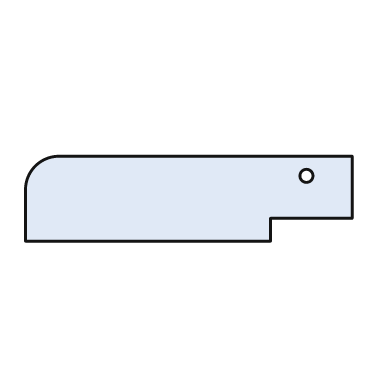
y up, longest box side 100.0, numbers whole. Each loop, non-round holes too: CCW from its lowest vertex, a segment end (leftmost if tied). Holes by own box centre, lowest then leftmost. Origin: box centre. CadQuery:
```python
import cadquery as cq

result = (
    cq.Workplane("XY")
    .moveTo(-50.0, -13.0)
    .lineTo(25.0, -13.0)
    .lineTo(25.0, -6.0)
    .lineTo(50.0, -6.0)
    .lineTo(50.0, 13.0)
    .lineTo(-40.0, 13.0)
    .threePointArc((-47.0, 10.0), (-50.0, 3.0))
    .close()
    .moveTo(36.0, 7.0)
    .circle(2.0)
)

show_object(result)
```